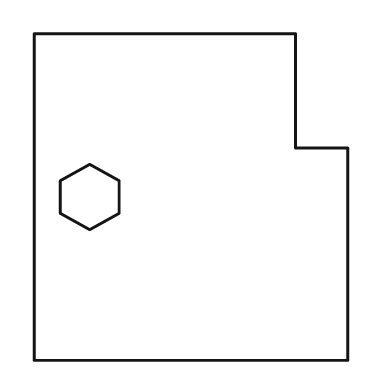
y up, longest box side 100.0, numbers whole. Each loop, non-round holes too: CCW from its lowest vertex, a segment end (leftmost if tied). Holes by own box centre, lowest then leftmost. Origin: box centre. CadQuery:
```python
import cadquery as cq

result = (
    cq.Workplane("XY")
    .moveTo(-48.0, -50.0)
    .lineTo(48.0, -50.0)
    .lineTo(48.0, 15.0)
    .lineTo(32.0, 15.0)
    .lineTo(32.0, 50.0)
    .lineTo(-48.0, 50.0)
    .close()
    .moveTo(-31.0, -10.0)
    .lineTo(-22.0, -5.0)
    .lineTo(-22.0, 5.0)
    .lineTo(-31.0, 10.0)
    .lineTo(-40.0, 5.0)
    .lineTo(-40.0, -5.0)
    .close()
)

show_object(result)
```